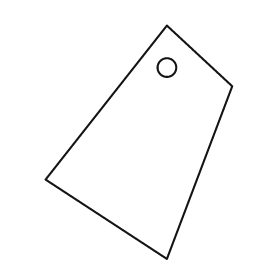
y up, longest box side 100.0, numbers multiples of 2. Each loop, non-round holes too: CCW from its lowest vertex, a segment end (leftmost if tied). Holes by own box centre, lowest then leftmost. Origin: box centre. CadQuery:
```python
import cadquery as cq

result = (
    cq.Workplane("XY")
    .moveTo(12.0, -50.0)
    .lineTo(40.0, 24.0)
    .lineTo(12.0, 50.0)
    .lineTo(-40.0, -16.0)
    .close()
    .moveTo(12.0, 32.0)
    .circle(4.0)
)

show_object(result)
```